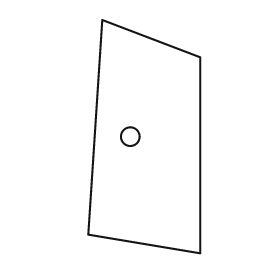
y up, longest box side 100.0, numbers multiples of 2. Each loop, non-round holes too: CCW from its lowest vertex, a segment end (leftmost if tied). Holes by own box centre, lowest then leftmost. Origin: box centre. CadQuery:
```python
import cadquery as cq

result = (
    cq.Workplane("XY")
    .moveTo(24.0, -50.0)
    .lineTo(24.0, 34.0)
    .lineTo(-18.0, 50.0)
    .lineTo(-24.0, -42.0)
    .close()
    .moveTo(-6.0, 0.0)
    .circle(4.0)
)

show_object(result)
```